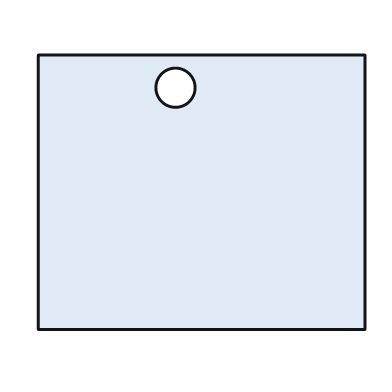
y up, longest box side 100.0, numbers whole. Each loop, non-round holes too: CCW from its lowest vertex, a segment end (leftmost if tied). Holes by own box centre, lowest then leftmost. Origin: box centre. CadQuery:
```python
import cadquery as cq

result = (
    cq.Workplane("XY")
    .moveTo(-50.0, -42.0)
    .lineTo(50.0, -42.0)
    .lineTo(50.0, 42.0)
    .lineTo(-50.0, 42.0)
    .close()
    .moveTo(-8.0, 32.0)
    .circle(6.0)
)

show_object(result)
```